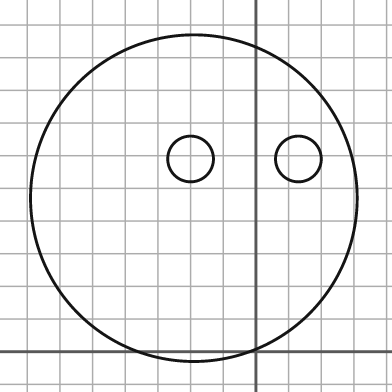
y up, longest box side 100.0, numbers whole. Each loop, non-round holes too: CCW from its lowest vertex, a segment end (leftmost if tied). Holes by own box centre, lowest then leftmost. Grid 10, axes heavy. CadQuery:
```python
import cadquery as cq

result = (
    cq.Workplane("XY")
    .moveTo(-19.0, 47.0)
    .circle(50.0)
    .moveTo(-20.0, 59.0)
    .circle(7.0)
    .moveTo(13.0, 59.0)
    .circle(7.0)
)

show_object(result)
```